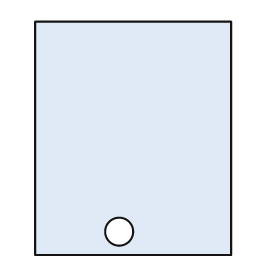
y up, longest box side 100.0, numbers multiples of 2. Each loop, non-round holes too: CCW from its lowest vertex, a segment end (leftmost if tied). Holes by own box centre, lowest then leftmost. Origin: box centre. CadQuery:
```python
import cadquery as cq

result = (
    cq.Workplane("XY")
    .moveTo(-42.0, -50.0)
    .lineTo(42.0, -50.0)
    .lineTo(42.0, 50.0)
    .lineTo(-42.0, 50.0)
    .close()
    .moveTo(-6.0, -40.0)
    .circle(6.0)
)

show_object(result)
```